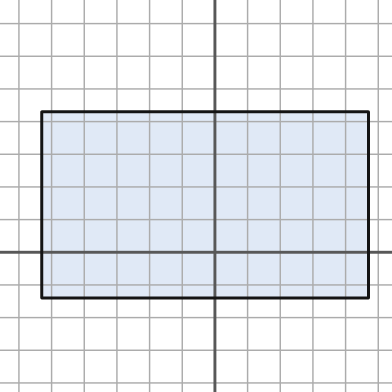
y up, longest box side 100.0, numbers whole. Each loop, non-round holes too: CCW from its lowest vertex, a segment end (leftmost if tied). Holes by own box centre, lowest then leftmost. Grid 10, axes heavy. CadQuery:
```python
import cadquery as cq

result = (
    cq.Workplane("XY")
    .moveTo(-53.0, -14.0)
    .lineTo(47.0, -14.0)
    .lineTo(47.0, 43.0)
    .lineTo(-53.0, 43.0)
    .close()
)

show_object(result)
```